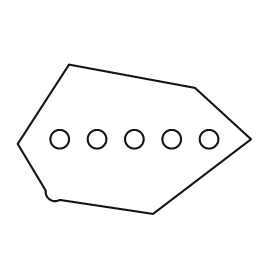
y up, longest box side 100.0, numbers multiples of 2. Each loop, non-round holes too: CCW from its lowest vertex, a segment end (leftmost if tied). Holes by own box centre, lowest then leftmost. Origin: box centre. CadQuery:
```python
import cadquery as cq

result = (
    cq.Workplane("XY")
    .moveTo(8.0, -32.0)
    .lineTo(50.0, 0.0)
    .lineTo(26.0, 22.0)
    .lineTo(-28.0, 32.0)
    .lineTo(-50.0, -2.0)
    .lineTo(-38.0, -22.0)
    .threePointArc((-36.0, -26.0), (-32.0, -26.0))
    .close()
    .moveTo(-32.0, 0.0)
    .circle(4.0)
    .moveTo(-16.0, 0.0)
    .circle(4.0)
    .moveTo(0.0, 0.0)
    .circle(4.0)
    .moveTo(16.0, 0.0)
    .circle(4.0)
    .moveTo(32.0, 0.0)
    .circle(4.0)
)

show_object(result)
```